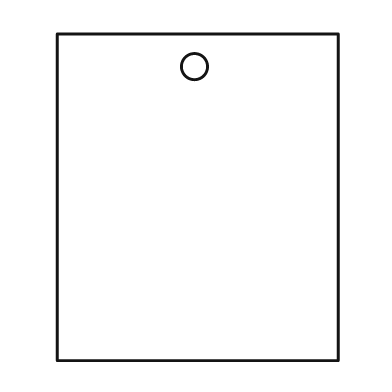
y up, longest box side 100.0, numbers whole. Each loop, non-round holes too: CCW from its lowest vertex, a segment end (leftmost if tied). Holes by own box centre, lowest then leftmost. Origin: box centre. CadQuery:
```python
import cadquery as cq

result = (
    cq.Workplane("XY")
    .moveTo(-43.0, -50.0)
    .lineTo(43.0, -50.0)
    .lineTo(43.0, 50.0)
    .lineTo(-43.0, 50.0)
    .close()
    .moveTo(-1.0, 40.0)
    .circle(4.0)
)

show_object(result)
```